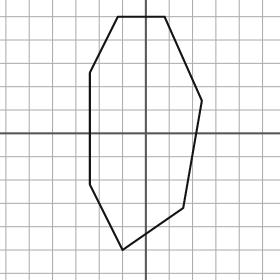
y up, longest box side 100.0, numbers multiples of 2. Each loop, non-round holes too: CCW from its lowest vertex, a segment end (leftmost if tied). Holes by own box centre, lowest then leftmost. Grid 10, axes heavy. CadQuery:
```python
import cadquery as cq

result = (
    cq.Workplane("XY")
    .moveTo(-10.0, -50.0)
    .lineTo(16.0, -32.0)
    .lineTo(24.0, 14.0)
    .lineTo(8.0, 50.0)
    .lineTo(-12.0, 50.0)
    .lineTo(-24.0, 26.0)
    .lineTo(-24.0, -22.0)
    .close()
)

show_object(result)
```